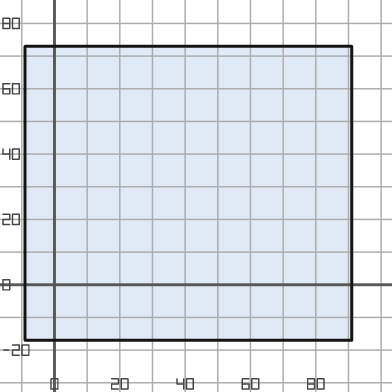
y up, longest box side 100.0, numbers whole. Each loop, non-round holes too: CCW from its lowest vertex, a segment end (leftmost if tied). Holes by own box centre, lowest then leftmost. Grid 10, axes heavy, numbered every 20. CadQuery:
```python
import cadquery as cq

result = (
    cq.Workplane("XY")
    .moveTo(-9.0, -17.0)
    .lineTo(91.0, -17.0)
    .lineTo(91.0, 73.0)
    .lineTo(-9.0, 73.0)
    .close()
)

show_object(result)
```